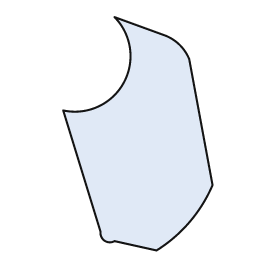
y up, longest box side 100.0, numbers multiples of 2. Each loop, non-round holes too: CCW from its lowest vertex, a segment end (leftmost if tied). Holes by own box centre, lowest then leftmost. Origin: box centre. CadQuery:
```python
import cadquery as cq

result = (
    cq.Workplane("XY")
    .moveTo(8.0, -50.0)
    .threePointArc((22.0, -38.0), (32.0, -22.0))
    .lineTo(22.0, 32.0)
    .threePointArc((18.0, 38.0), (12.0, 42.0))
    .lineTo(-10.0, 50.0)
    .threePointArc((-6.0, 22.0), (-32.0, 10.0))
    .lineTo(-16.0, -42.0)
    .threePointArc((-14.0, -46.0), (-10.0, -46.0))
    .close()
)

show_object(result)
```